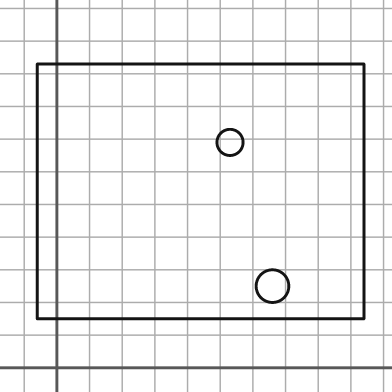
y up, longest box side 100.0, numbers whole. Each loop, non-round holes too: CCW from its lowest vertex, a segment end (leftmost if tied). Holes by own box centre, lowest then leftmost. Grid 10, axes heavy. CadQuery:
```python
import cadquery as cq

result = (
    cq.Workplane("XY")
    .moveTo(-6.0, 15.0)
    .lineTo(94.0, 15.0)
    .lineTo(94.0, 93.0)
    .lineTo(-6.0, 93.0)
    .close()
    .moveTo(66.0, 25.0)
    .circle(5.0)
    .moveTo(53.0, 69.0)
    .circle(4.0)
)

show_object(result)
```